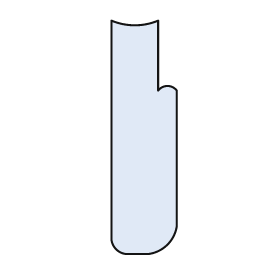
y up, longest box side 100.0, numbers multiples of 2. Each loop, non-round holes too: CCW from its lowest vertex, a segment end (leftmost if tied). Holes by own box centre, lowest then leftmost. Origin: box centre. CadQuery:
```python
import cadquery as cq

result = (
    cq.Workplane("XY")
    .moveTo(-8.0, -50.0)
    .lineTo(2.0, -50.0)
    .threePointArc((10.0, -46.0), (14.0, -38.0))
    .lineTo(14.0, 20.0)
    .threePointArc((10.0, 22.0), (6.0, 20.0))
    .lineTo(6.0, 50.0)
    .threePointArc((-4.0, 48.0), (-14.0, 50.0))
    .lineTo(-14.0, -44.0)
    .threePointArc((-12.0, -48.0), (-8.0, -50.0))
    .close()
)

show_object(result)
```